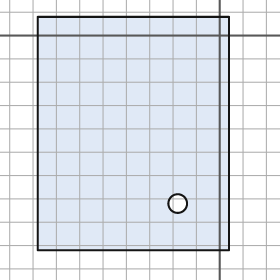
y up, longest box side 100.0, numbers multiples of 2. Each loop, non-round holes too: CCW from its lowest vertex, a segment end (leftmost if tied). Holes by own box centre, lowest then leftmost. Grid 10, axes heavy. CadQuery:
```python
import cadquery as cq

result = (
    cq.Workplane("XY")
    .moveTo(-78.0, -92.0)
    .lineTo(4.0, -92.0)
    .lineTo(4.0, 8.0)
    .lineTo(-78.0, 8.0)
    .close()
    .moveTo(-18.0, -72.0)
    .circle(4.0)
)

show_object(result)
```